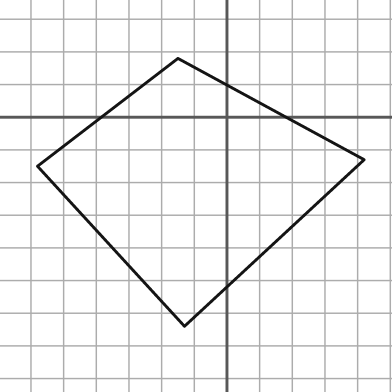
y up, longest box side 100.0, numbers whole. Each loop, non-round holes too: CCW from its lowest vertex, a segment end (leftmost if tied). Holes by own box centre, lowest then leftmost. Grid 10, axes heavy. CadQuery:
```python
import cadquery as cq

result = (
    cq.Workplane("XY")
    .moveTo(-13.0, -64.0)
    .lineTo(42.0, -13.0)
    .lineTo(-15.0, 18.0)
    .lineTo(-58.0, -15.0)
    .close()
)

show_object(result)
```